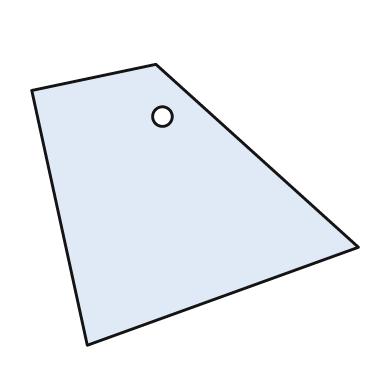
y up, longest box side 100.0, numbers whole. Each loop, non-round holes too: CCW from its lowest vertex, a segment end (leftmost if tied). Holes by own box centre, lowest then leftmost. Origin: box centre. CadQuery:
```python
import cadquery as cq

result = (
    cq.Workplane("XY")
    .moveTo(-33.0, -43.0)
    .lineTo(50.0, -13.0)
    .lineTo(-12.0, 43.0)
    .lineTo(-50.0, 35.0)
    .close()
    .moveTo(-10.0, 27.0)
    .circle(3.0)
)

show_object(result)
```